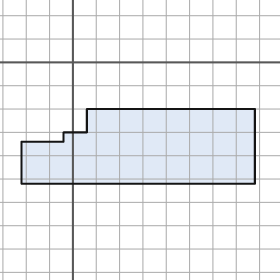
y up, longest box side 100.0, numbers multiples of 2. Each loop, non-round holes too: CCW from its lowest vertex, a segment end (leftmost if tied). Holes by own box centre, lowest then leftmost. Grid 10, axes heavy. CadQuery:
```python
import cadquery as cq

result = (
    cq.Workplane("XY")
    .moveTo(-22.0, -52.0)
    .lineTo(78.0, -52.0)
    .lineTo(78.0, -20.0)
    .lineTo(6.0, -20.0)
    .lineTo(6.0, -30.0)
    .lineTo(-4.0, -30.0)
    .lineTo(-4.0, -34.0)
    .lineTo(-22.0, -34.0)
    .close()
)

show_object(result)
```